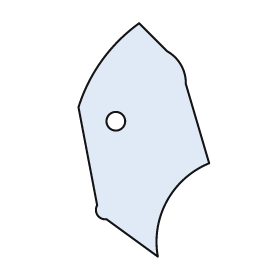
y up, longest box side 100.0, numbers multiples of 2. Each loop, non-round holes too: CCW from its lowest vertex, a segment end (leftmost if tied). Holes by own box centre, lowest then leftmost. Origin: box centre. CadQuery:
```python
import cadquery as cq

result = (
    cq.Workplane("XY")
    .moveTo(6.0, -50.0)
    .threePointArc((10.0, -26.0), (28.0, -10.0))
    .lineTo(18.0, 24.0)
    .threePointArc((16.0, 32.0), (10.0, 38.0))
    .lineTo(-2.0, 50.0)
    .threePointArc((-18.0, 34.0), (-28.0, 14.0))
    .lineTo(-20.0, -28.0)
    .threePointArc((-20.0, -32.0), (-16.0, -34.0))
    .close()
    .moveTo(-12.0, 8.0)
    .circle(4.0)
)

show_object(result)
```